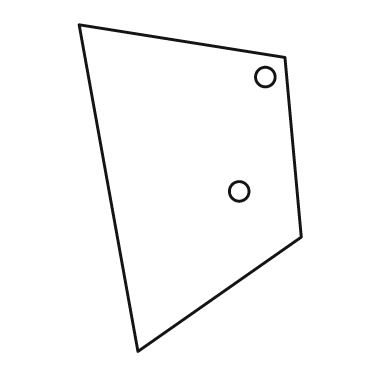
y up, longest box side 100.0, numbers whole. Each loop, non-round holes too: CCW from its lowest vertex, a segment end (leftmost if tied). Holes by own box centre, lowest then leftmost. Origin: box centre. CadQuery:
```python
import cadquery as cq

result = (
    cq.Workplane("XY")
    .moveTo(-16.0, -50.0)
    .lineTo(34.0, -15.0)
    .lineTo(29.0, 40.0)
    .lineTo(-34.0, 50.0)
    .close()
    .moveTo(15.0, -1.0)
    .circle(3.0)
    .moveTo(23.0, 34.0)
    .circle(3.0)
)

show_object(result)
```